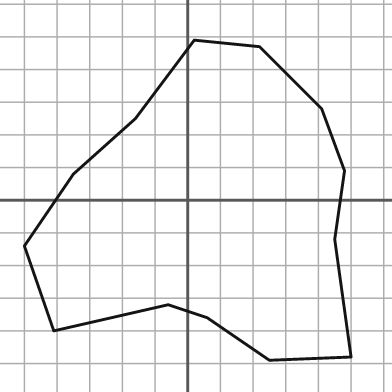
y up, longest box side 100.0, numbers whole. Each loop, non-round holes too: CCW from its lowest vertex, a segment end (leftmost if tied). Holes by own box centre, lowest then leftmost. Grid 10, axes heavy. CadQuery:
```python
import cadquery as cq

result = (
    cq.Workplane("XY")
    .moveTo(25.0, -49.0)
    .lineTo(50.0, -48.0)
    .lineTo(45.0, -12.0)
    .lineTo(48.0, 9.0)
    .lineTo(41.0, 28.0)
    .lineTo(22.0, 47.0)
    .lineTo(2.0, 49.0)
    .lineTo(-16.0, 25.0)
    .lineTo(-35.0, 8.0)
    .lineTo(-50.0, -14.0)
    .lineTo(-41.0, -40.0)
    .lineTo(-6.0, -32.0)
    .lineTo(6.0, -36.0)
    .close()
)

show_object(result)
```